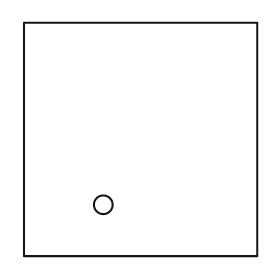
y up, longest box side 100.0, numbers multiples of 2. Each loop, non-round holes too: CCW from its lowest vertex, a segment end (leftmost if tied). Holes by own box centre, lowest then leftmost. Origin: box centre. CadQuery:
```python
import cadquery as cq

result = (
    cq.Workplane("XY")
    .moveTo(-50.0, -50.0)
    .lineTo(50.0, -50.0)
    .lineTo(50.0, 50.0)
    .lineTo(-50.0, 50.0)
    .close()
    .moveTo(-16.0, -28.0)
    .circle(4.0)
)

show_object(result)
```